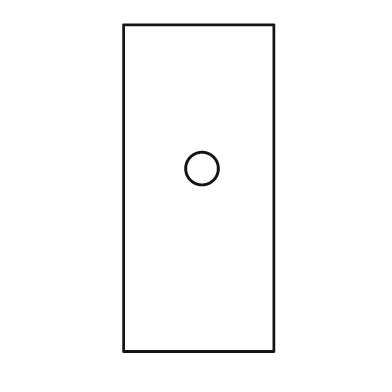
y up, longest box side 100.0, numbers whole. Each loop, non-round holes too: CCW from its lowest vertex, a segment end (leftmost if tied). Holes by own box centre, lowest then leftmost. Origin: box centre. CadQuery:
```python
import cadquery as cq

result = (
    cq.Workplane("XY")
    .moveTo(-23.0, -50.0)
    .lineTo(23.0, -50.0)
    .lineTo(23.0, 50.0)
    .lineTo(-23.0, 50.0)
    .close()
    .moveTo(1.0, 6.0)
    .circle(5.0)
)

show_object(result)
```